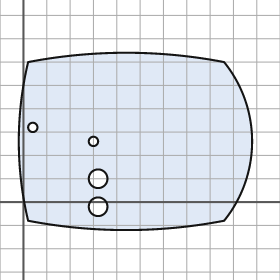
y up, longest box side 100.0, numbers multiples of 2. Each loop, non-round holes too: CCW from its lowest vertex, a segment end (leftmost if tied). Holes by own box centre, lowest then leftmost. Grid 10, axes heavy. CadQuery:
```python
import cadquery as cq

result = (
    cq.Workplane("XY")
    .moveTo(2.0, -8.0)
    .threePointArc((44.0, -12.0), (86.0, -8.0))
    .threePointArc((98.0, 26.0), (86.0, 60.0))
    .threePointArc((44.0, 64.0), (2.0, 60.0))
    .threePointArc((-2.0, 26.0), (2.0, -8.0))
    .close()
    .moveTo(32.0, -2.0)
    .circle(4.0)
    .moveTo(32.0, 10.0)
    .circle(4.0)
    .moveTo(30.0, 26.0)
    .circle(2.0)
    .moveTo(4.0, 32.0)
    .circle(2.0)
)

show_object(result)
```